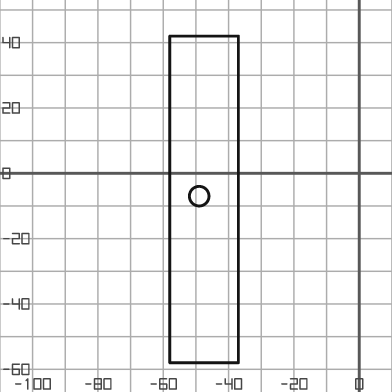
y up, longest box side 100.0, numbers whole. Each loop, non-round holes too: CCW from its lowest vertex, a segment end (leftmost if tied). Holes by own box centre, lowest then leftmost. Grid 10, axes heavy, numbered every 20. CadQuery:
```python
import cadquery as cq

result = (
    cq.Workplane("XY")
    .moveTo(-58.0, -58.0)
    .lineTo(-37.0, -58.0)
    .lineTo(-37.0, 42.0)
    .lineTo(-58.0, 42.0)
    .close()
    .moveTo(-49.0, -7.0)
    .circle(3.0)
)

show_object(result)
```